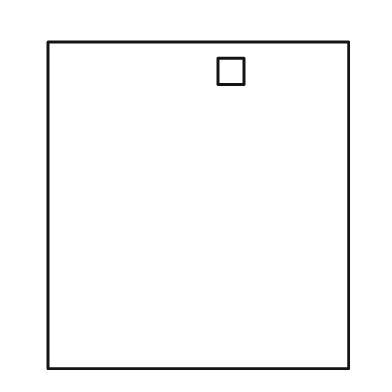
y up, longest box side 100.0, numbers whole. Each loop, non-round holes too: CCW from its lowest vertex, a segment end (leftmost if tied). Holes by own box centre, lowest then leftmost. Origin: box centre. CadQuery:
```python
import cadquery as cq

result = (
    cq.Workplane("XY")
    .moveTo(-46.0, -50.0)
    .lineTo(46.0, -50.0)
    .lineTo(46.0, 50.0)
    .lineTo(-46.0, 50.0)
    .close()
    .moveTo(6.0, 37.0)
    .lineTo(14.0, 37.0)
    .lineTo(14.0, 45.0)
    .lineTo(6.0, 45.0)
    .close()
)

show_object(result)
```